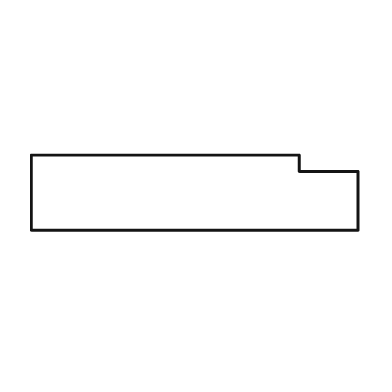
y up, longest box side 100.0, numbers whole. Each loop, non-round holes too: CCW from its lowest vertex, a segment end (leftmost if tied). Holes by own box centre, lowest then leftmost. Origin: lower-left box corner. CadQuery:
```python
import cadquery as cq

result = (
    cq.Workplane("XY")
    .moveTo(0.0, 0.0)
    .lineTo(100.0, 0.0)
    .lineTo(100.0, 18.0)
    .lineTo(82.0, 18.0)
    .lineTo(82.0, 23.0)
    .lineTo(0.0, 23.0)
    .close()
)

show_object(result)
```